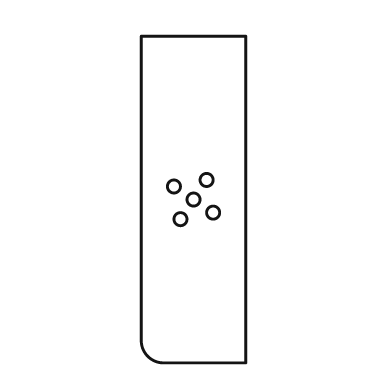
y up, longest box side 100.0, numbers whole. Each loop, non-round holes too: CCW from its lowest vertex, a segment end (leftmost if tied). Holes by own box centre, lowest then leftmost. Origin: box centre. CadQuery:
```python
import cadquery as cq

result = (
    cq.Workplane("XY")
    .moveTo(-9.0, -50.0)
    .lineTo(16.0, -50.0)
    .lineTo(16.0, 50.0)
    .lineTo(-16.0, 50.0)
    .lineTo(-16.0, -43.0)
    .threePointArc((-14.0, -48.0), (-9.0, -50.0))
    .close()
    .moveTo(-4.0, -6.0)
    .circle(2.0)
    .moveTo(6.0, -4.0)
    .circle(2.0)
    .moveTo(0.0, 0.0)
    .circle(2.0)
    .moveTo(-6.0, 4.0)
    .circle(2.0)
    .moveTo(4.0, 6.0)
    .circle(2.0)
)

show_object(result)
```